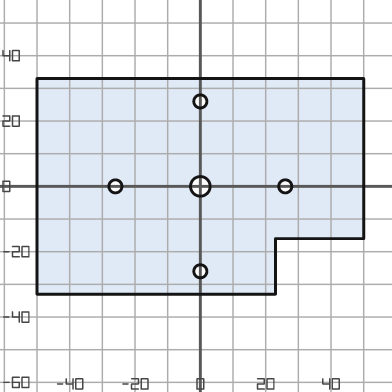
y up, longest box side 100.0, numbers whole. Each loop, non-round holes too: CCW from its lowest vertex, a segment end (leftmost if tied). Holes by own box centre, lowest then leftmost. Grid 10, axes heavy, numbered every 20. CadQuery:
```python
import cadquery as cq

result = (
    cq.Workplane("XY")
    .moveTo(-50.0, -33.0)
    .lineTo(23.0, -33.0)
    .lineTo(23.0, -16.0)
    .lineTo(50.0, -16.0)
    .lineTo(50.0, 33.0)
    .lineTo(-50.0, 33.0)
    .close()
    .moveTo(0.0, -26.0)
    .circle(2.0)
    .moveTo(-26.0, 0.0)
    .circle(2.0)
    .moveTo(0.0, 0.0)
    .circle(3.0)
    .moveTo(26.0, 0.0)
    .circle(2.0)
    .moveTo(0.0, 26.0)
    .circle(2.0)
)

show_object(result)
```